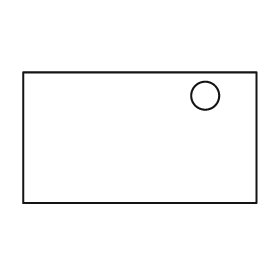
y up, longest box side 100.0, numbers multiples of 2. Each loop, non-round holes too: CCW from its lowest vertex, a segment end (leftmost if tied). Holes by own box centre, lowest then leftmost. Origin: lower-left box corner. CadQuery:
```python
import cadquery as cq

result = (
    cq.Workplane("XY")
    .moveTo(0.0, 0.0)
    .lineTo(100.0, 0.0)
    .lineTo(100.0, 56.0)
    .lineTo(0.0, 56.0)
    .close()
    .moveTo(78.0, 46.0)
    .circle(6.0)
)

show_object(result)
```